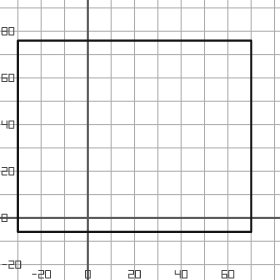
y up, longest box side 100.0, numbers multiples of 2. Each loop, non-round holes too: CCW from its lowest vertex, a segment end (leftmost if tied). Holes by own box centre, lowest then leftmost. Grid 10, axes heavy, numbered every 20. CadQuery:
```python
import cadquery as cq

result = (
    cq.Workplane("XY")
    .moveTo(-30.0, -6.0)
    .lineTo(70.0, -6.0)
    .lineTo(70.0, 76.0)
    .lineTo(-30.0, 76.0)
    .close()
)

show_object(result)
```